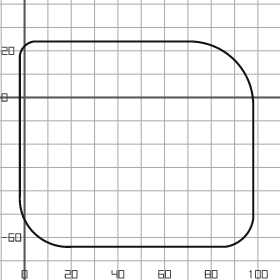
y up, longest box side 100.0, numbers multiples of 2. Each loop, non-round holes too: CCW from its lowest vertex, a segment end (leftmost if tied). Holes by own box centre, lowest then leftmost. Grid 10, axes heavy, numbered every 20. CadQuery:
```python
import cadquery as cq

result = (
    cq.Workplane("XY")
    .moveTo(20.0, -64.0)
    .lineTo(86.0, -64.0)
    .threePointArc((94.0, -60.0), (98.0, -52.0))
    .lineTo(98.0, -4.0)
    .threePointArc((90.0, 16.0), (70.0, 24.0))
    .lineTo(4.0, 24.0)
    .threePointArc((0.0, 22.0), (-2.0, 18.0))
    .lineTo(-2.0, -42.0)
    .threePointArc((4.0, -58.0), (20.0, -64.0))
    .close()
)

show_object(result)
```